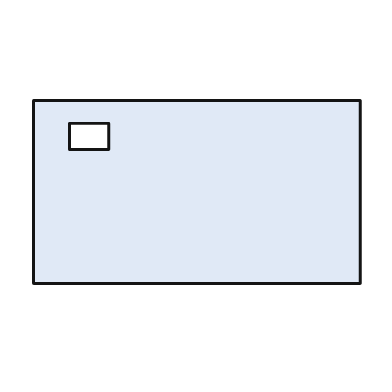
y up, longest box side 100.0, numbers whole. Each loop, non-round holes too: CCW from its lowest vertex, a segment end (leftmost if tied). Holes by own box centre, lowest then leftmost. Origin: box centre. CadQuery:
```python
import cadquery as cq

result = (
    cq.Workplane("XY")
    .moveTo(-50.0, -28.0)
    .lineTo(50.0, -28.0)
    .lineTo(50.0, 28.0)
    .lineTo(-50.0, 28.0)
    .close()
    .moveTo(-39.0, 13.0)
    .lineTo(-27.0, 13.0)
    .lineTo(-27.0, 21.0)
    .lineTo(-39.0, 21.0)
    .close()
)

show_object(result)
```